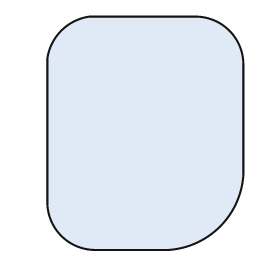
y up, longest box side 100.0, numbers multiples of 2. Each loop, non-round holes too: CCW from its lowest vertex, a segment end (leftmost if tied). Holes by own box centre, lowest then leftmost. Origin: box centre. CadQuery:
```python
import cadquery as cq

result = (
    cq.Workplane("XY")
    .moveTo(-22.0, -50.0)
    .lineTo(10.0, -50.0)
    .threePointArc((32.0, -40.0), (42.0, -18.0))
    .lineTo(42.0, 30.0)
    .threePointArc((36.0, 44.0), (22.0, 50.0))
    .lineTo(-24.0, 50.0)
    .threePointArc((-36.0, 44.0), (-42.0, 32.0))
    .lineTo(-42.0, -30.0)
    .threePointArc((-36.0, -44.0), (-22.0, -50.0))
    .close()
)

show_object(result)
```